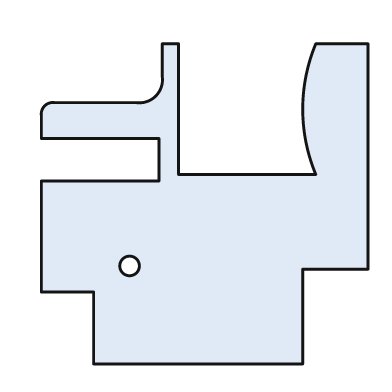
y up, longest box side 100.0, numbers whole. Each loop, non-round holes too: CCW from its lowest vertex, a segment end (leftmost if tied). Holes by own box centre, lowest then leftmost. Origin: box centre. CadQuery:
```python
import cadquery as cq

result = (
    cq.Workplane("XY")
    .moveTo(-34.0, -49.0)
    .lineTo(30.0, -49.0)
    .lineTo(30.0, -20.0)
    .lineTo(50.0, -20.0)
    .lineTo(50.0, 49.0)
    .lineTo(34.0, 49.0)
    .threePointArc((30.0, 29.0), (34.0, 9.0))
    .lineTo(-8.0, 9.0)
    .lineTo(-8.0, 49.0)
    .lineTo(-13.0, 49.0)
    .lineTo(-13.0, 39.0)
    .threePointArc((-15.0, 33.0), (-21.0, 31.0))
    .lineTo(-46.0, 31.0)
    .threePointArc((-49.0, 30.0), (-50.0, 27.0))
    .lineTo(-50.0, 20.0)
    .lineTo(-14.0, 20.0)
    .lineTo(-14.0, 7.0)
    .lineTo(-50.0, 7.0)
    .lineTo(-50.0, -27.0)
    .lineTo(-34.0, -27.0)
    .close()
    .moveTo(-23.0, -19.0)
    .circle(3.0)
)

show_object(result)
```